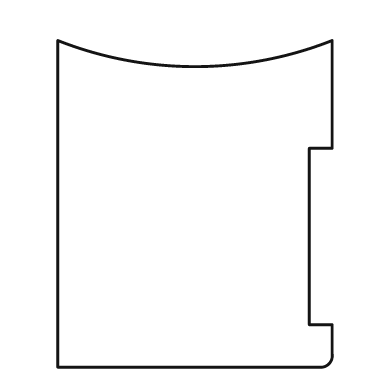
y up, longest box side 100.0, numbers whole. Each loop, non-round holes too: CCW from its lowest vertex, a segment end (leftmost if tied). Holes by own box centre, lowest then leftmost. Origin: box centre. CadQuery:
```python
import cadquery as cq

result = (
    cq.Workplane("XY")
    .moveTo(-42.0, -50.0)
    .lineTo(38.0, -50.0)
    .threePointArc((41.0, -49.0), (42.0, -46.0))
    .lineTo(42.0, -37.0)
    .lineTo(35.0, -37.0)
    .lineTo(35.0, 17.0)
    .lineTo(42.0, 17.0)
    .lineTo(42.0, 50.0)
    .threePointArc((0.0, 42.0), (-42.0, 50.0))
    .close()
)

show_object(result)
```